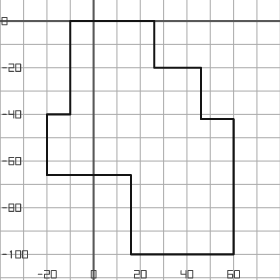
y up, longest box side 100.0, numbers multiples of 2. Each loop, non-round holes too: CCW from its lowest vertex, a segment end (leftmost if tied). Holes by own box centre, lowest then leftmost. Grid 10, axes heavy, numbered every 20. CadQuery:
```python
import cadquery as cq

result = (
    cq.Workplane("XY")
    .moveTo(16.0, -100.0)
    .lineTo(60.0, -100.0)
    .lineTo(60.0, -42.0)
    .lineTo(46.0, -42.0)
    .lineTo(46.0, -20.0)
    .lineTo(26.0, -20.0)
    .lineTo(26.0, 0.0)
    .lineTo(-10.0, 0.0)
    .lineTo(-10.0, -40.0)
    .lineTo(-20.0, -40.0)
    .lineTo(-20.0, -66.0)
    .lineTo(16.0, -66.0)
    .close()
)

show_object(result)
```